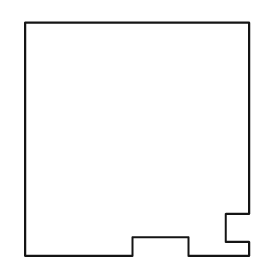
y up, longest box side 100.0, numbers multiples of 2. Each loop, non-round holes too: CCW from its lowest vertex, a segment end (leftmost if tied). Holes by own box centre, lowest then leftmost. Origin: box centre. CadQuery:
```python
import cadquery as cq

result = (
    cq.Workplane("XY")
    .moveTo(-48.0, -50.0)
    .lineTo(-2.0, -50.0)
    .lineTo(-2.0, -42.0)
    .lineTo(22.0, -42.0)
    .lineTo(22.0, -50.0)
    .lineTo(48.0, -50.0)
    .lineTo(48.0, -44.0)
    .lineTo(38.0, -44.0)
    .lineTo(38.0, -32.0)
    .lineTo(48.0, -32.0)
    .lineTo(48.0, 50.0)
    .lineTo(-48.0, 50.0)
    .close()
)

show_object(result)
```